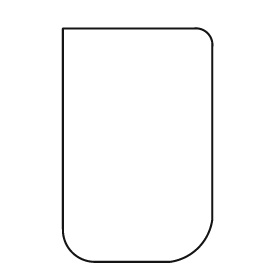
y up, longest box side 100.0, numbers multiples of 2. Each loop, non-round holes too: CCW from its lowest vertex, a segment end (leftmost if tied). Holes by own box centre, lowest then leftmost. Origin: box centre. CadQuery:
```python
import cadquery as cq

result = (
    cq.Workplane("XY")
    .moveTo(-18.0, -50.0)
    .lineTo(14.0, -50.0)
    .threePointArc((26.0, -44.0), (32.0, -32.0))
    .lineTo(32.0, 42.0)
    .threePointArc((30.0, 48.0), (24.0, 50.0))
    .lineTo(-32.0, 50.0)
    .lineTo(-32.0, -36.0)
    .threePointArc((-28.0, -46.0), (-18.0, -50.0))
    .close()
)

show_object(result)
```